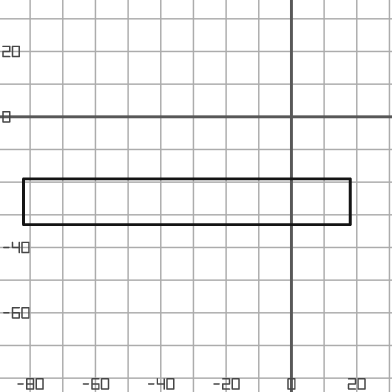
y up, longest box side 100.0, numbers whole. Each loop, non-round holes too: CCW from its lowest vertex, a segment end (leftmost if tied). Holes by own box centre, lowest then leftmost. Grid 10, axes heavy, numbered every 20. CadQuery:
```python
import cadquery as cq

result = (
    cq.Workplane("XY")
    .moveTo(-82.0, -33.0)
    .lineTo(18.0, -33.0)
    .lineTo(18.0, -19.0)
    .lineTo(-82.0, -19.0)
    .close()
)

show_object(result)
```